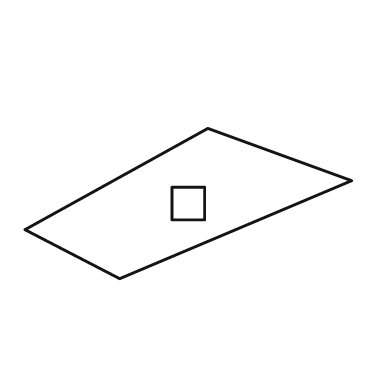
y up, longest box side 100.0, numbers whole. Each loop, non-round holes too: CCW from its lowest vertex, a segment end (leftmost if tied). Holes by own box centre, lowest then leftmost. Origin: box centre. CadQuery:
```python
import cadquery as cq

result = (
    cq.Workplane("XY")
    .moveTo(-21.0, -23.0)
    .lineTo(50.0, 7.0)
    .lineTo(6.0, 23.0)
    .lineTo(-50.0, -8.0)
    .close()
    .moveTo(-5.0, -5.0)
    .lineTo(5.0, -5.0)
    .lineTo(5.0, 5.0)
    .lineTo(-5.0, 5.0)
    .close()
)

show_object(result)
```